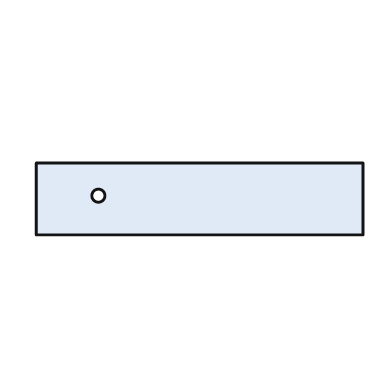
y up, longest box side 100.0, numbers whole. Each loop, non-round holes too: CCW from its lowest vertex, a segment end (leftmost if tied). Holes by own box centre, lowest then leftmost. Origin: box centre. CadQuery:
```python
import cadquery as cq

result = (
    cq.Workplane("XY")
    .moveTo(-50.0, -11.0)
    .lineTo(50.0, -11.0)
    .lineTo(50.0, 11.0)
    .lineTo(-50.0, 11.0)
    .close()
    .moveTo(-31.0, 1.0)
    .circle(2.0)
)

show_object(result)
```